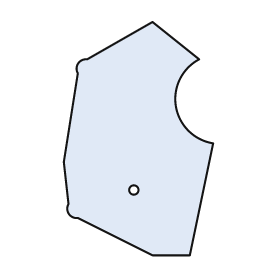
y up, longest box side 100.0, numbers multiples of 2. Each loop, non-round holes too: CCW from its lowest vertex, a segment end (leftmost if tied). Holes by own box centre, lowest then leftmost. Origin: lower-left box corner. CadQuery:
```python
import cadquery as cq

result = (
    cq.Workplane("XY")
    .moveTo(38.0, 0.0)
    .lineTo(54.0, 0.0)
    .lineTo(64.0, 48.0)
    .threePointArc((48.0, 64.0), (58.0, 84.0))
    .lineTo(38.0, 100.0)
    .lineTo(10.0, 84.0)
    .threePointArc((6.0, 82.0), (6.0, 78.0))
    .lineTo(0.0, 40.0)
    .lineTo(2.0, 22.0)
    .threePointArc((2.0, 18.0), (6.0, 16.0))
    .close()
    .moveTo(30.0, 28.0)
    .circle(2.0)
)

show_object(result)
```